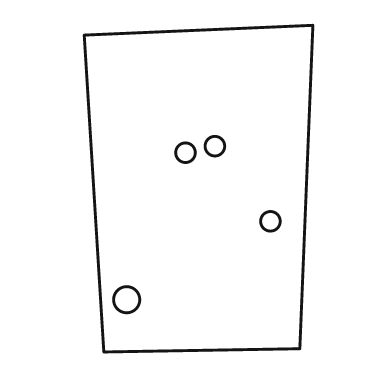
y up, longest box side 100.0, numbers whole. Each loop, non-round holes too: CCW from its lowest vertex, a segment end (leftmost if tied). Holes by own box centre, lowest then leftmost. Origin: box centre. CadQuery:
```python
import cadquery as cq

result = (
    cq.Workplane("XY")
    .moveTo(-29.0, -50.0)
    .lineTo(31.0, -49.0)
    .lineTo(35.0, 50.0)
    .lineTo(-35.0, 47.0)
    .close()
    .moveTo(-22.0, -34.0)
    .circle(4.0)
    .moveTo(22.0, -10.0)
    .circle(3.0)
    .moveTo(-4.0, 11.0)
    .circle(3.0)
    .moveTo(5.0, 13.0)
    .circle(3.0)
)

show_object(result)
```